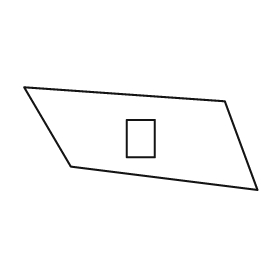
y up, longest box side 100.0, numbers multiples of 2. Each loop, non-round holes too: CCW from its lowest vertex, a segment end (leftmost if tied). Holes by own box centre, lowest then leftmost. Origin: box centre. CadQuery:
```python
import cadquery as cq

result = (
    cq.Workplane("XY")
    .moveTo(50.0, -22.0)
    .lineTo(36.0, 16.0)
    .lineTo(-50.0, 22.0)
    .lineTo(-30.0, -12.0)
    .close()
    .moveTo(-6.0, -8.0)
    .lineTo(6.0, -8.0)
    .lineTo(6.0, 8.0)
    .lineTo(-6.0, 8.0)
    .close()
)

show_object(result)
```